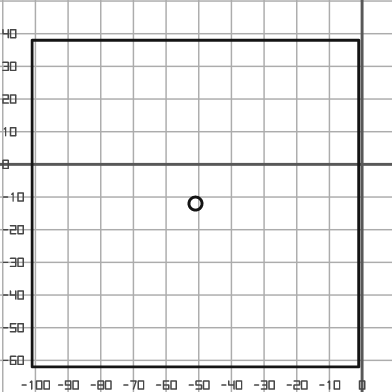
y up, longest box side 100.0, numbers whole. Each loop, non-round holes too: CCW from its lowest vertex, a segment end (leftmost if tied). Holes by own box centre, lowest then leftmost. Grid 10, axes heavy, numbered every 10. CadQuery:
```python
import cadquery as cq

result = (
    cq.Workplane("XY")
    .moveTo(-101.0, -62.0)
    .lineTo(-1.0, -62.0)
    .lineTo(-1.0, 38.0)
    .lineTo(-101.0, 38.0)
    .close()
    .moveTo(-51.0, -12.0)
    .circle(2.0)
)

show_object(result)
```